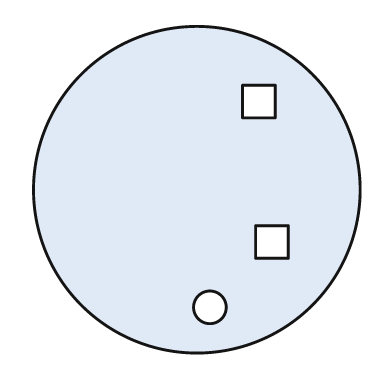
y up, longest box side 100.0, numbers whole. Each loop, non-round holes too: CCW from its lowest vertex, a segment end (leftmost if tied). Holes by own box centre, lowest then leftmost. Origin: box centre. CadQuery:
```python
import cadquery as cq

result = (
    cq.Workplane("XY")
    .moveTo(0.0, 0.0)
    .circle(50.0)
    .moveTo(4.0, -36.0)
    .circle(5.0)
    .moveTo(18.0, -21.0)
    .lineTo(28.0, -21.0)
    .lineTo(28.0, -11.0)
    .lineTo(18.0, -11.0)
    .close()
    .moveTo(14.0, 22.0)
    .lineTo(24.0, 22.0)
    .lineTo(24.0, 32.0)
    .lineTo(14.0, 32.0)
    .close()
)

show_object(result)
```